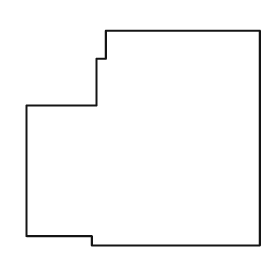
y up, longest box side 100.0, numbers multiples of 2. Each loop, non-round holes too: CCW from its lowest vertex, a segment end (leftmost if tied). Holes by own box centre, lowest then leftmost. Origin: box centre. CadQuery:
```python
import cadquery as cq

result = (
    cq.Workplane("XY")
    .moveTo(-22.0, -46.0)
    .lineTo(50.0, -46.0)
    .lineTo(50.0, 46.0)
    .lineTo(-16.0, 46.0)
    .lineTo(-16.0, 34.0)
    .lineTo(-20.0, 34.0)
    .lineTo(-20.0, 14.0)
    .lineTo(-50.0, 14.0)
    .lineTo(-50.0, -42.0)
    .lineTo(-22.0, -42.0)
    .close()
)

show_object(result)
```